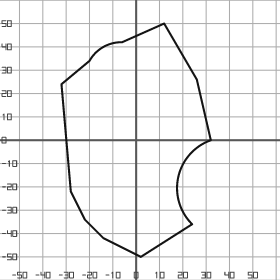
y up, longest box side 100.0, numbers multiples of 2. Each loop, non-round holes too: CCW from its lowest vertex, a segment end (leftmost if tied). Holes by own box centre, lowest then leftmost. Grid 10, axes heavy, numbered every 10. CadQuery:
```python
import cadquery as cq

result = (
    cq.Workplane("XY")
    .moveTo(2.0, -50.0)
    .lineTo(24.0, -36.0)
    .threePointArc((18.0, -16.0), (32.0, 0.0))
    .lineTo(26.0, 26.0)
    .lineTo(12.0, 50.0)
    .lineTo(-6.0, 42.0)
    .threePointArc((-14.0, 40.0), (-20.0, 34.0))
    .lineTo(-32.0, 24.0)
    .lineTo(-28.0, -22.0)
    .lineTo(-22.0, -34.0)
    .lineTo(-14.0, -42.0)
    .close()
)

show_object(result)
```